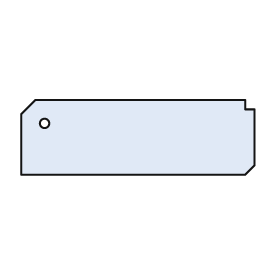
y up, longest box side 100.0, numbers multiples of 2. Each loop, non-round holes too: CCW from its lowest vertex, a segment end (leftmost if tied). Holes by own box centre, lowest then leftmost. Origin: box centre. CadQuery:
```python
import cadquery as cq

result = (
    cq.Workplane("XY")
    .moveTo(-50.0, -16.0)
    .lineTo(46.0, -16.0)
    .lineTo(50.0, -12.0)
    .lineTo(50.0, 12.0)
    .lineTo(46.0, 12.0)
    .lineTo(46.0, 16.0)
    .lineTo(-44.0, 16.0)
    .lineTo(-50.0, 10.0)
    .close()
    .moveTo(-40.0, 6.0)
    .circle(2.0)
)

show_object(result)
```